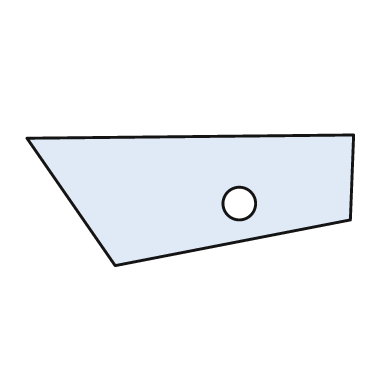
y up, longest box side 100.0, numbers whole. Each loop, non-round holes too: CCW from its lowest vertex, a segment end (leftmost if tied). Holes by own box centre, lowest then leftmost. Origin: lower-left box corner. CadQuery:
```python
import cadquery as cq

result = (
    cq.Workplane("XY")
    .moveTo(27.0, 0.0)
    .lineTo(99.0, 14.0)
    .lineTo(100.0, 40.0)
    .lineTo(0.0, 39.0)
    .close()
    .moveTo(65.0, 19.0)
    .circle(5.0)
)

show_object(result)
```